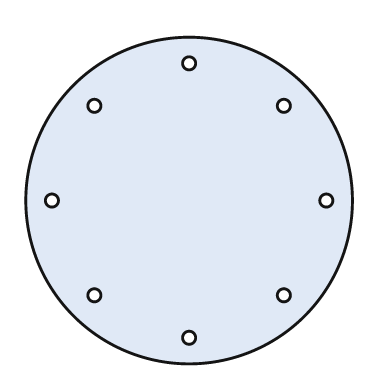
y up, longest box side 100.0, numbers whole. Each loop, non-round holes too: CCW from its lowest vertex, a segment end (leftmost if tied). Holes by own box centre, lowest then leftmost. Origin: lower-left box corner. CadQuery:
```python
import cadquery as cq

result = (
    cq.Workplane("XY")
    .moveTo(50.0, 50.0)
    .circle(50.0)
    .moveTo(50.0, 8.0)
    .circle(2.0)
    .moveTo(21.0, 21.0)
    .circle(2.0)
    .moveTo(79.0, 21.0)
    .circle(2.0)
    .moveTo(8.0, 50.0)
    .circle(2.0)
    .moveTo(92.0, 50.0)
    .circle(2.0)
    .moveTo(21.0, 79.0)
    .circle(2.0)
    .moveTo(79.0, 79.0)
    .circle(2.0)
    .moveTo(50.0, 92.0)
    .circle(2.0)
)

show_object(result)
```